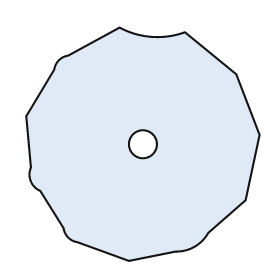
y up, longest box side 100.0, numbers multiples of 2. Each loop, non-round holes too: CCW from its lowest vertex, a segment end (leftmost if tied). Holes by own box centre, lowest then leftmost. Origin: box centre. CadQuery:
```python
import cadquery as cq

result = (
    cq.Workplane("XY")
    .moveTo(-6.0, -50.0)
    .lineTo(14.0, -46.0)
    .threePointArc((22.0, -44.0), (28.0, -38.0))
    .lineTo(44.0, -24.0)
    .lineTo(50.0, 4.0)
    .lineTo(40.0, 30.0)
    .lineTo(18.0, 48.0)
    .threePointArc((4.0, 46.0), (-10.0, 50.0))
    .lineTo(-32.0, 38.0)
    .threePointArc((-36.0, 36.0), (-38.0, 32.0))
    .lineTo(-50.0, 12.0)
    .lineTo(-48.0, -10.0)
    .threePointArc((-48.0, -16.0), (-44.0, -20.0))
    .lineTo(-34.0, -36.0)
    .threePointArc((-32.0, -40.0), (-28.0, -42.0))
    .close()
    .moveTo(0.0, 0.0)
    .circle(6.0)
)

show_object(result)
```